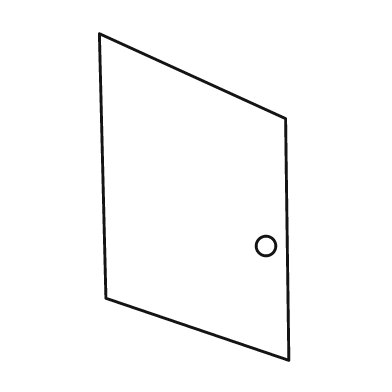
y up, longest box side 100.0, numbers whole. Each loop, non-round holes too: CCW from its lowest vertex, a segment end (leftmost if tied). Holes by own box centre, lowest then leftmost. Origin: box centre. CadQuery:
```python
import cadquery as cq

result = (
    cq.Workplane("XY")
    .moveTo(29.0, -50.0)
    .lineTo(28.0, 24.0)
    .lineTo(-29.0, 50.0)
    .lineTo(-27.0, -31.0)
    .close()
    .moveTo(22.0, -15.0)
    .circle(3.0)
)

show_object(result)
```